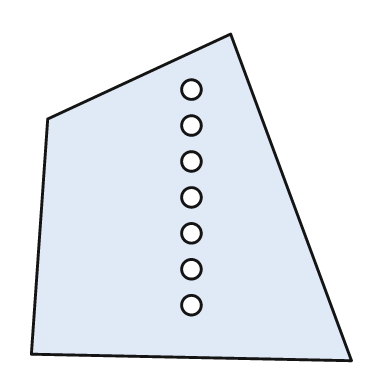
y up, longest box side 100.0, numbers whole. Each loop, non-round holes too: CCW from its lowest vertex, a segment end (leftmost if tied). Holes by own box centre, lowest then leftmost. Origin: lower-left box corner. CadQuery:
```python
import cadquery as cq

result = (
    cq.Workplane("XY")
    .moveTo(98.0, 0.0)
    .lineTo(61.0, 100.0)
    .lineTo(5.0, 74.0)
    .lineTo(0.0, 2.0)
    .close()
    .moveTo(49.0, 17.0)
    .circle(3.0)
    .moveTo(49.0, 28.0)
    .circle(3.0)
    .moveTo(49.0, 39.0)
    .circle(3.0)
    .moveTo(49.0, 50.0)
    .circle(3.0)
    .moveTo(49.0, 61.0)
    .circle(3.0)
    .moveTo(49.0, 72.0)
    .circle(3.0)
    .moveTo(49.0, 83.0)
    .circle(3.0)
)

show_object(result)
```